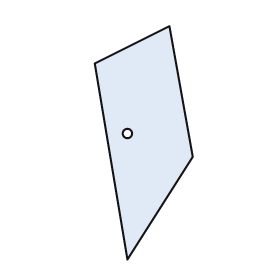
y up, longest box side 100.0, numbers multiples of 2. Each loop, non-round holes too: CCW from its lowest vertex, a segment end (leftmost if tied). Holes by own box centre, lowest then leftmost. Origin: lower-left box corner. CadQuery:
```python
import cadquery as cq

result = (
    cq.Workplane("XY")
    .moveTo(14.0, 0.0)
    .lineTo(42.0, 44.0)
    .lineTo(32.0, 100.0)
    .lineTo(0.0, 84.0)
    .close()
    .moveTo(14.0, 54.0)
    .circle(2.0)
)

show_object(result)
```